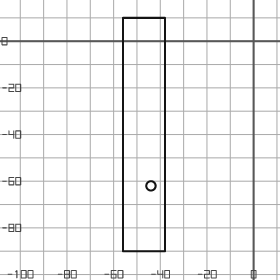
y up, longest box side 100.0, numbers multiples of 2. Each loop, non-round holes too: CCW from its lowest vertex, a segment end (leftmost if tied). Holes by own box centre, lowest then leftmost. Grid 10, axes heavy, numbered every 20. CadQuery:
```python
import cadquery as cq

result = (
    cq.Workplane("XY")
    .moveTo(-56.0, -90.0)
    .lineTo(-38.0, -90.0)
    .lineTo(-38.0, 10.0)
    .lineTo(-56.0, 10.0)
    .close()
    .moveTo(-44.0, -62.0)
    .circle(2.0)
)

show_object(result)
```